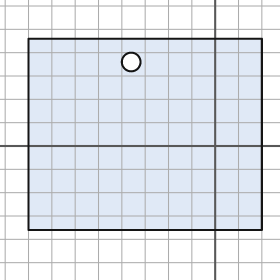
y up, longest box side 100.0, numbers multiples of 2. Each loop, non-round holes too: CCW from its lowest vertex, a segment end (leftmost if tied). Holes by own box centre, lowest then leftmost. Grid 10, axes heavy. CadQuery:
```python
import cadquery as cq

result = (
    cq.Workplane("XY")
    .moveTo(-80.0, -36.0)
    .lineTo(20.0, -36.0)
    .lineTo(20.0, 46.0)
    .lineTo(-80.0, 46.0)
    .close()
    .moveTo(-36.0, 36.0)
    .circle(4.0)
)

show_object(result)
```